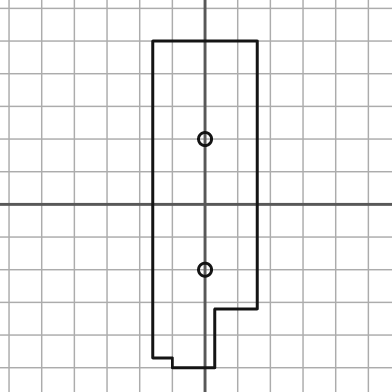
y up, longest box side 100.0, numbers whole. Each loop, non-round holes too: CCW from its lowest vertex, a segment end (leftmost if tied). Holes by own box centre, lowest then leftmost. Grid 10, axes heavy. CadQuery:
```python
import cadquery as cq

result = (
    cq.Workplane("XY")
    .moveTo(-10.0, -50.0)
    .lineTo(3.0, -50.0)
    .lineTo(3.0, -32.0)
    .lineTo(16.0, -32.0)
    .lineTo(16.0, 50.0)
    .lineTo(-16.0, 50.0)
    .lineTo(-16.0, -47.0)
    .lineTo(-10.0, -47.0)
    .close()
    .moveTo(0.0, -20.0)
    .circle(2.0)
    .moveTo(0.0, 20.0)
    .circle(2.0)
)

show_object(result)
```